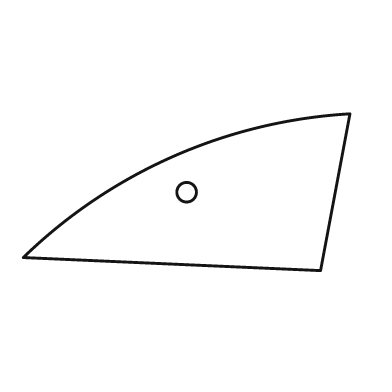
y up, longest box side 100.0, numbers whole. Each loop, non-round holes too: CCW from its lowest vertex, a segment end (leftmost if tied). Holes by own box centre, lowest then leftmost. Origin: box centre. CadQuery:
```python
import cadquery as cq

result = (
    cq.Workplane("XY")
    .moveTo(41.0, -24.0)
    .lineTo(50.0, 24.0)
    .threePointArc((-4.0, 11.0), (-50.0, -20.0))
    .close()
    .moveTo(0.0, 0.0)
    .circle(3.0)
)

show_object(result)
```